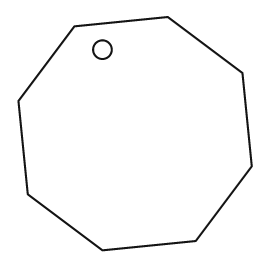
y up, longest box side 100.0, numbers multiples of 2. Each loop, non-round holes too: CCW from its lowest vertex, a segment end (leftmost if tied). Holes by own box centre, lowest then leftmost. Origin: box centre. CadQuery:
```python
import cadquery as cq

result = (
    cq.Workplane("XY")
    .moveTo(-14.0, -50.0)
    .lineTo(26.0, -46.0)
    .lineTo(50.0, -14.0)
    .lineTo(46.0, 26.0)
    .lineTo(14.0, 50.0)
    .lineTo(-26.0, 46.0)
    .lineTo(-50.0, 14.0)
    .lineTo(-46.0, -26.0)
    .close()
    .moveTo(-14.0, 36.0)
    .circle(4.0)
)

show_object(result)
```